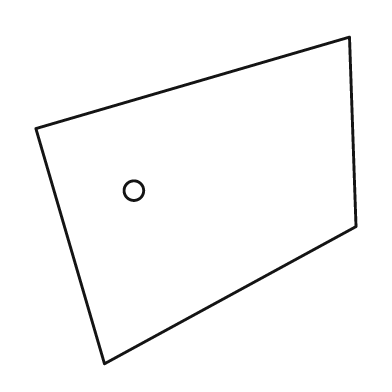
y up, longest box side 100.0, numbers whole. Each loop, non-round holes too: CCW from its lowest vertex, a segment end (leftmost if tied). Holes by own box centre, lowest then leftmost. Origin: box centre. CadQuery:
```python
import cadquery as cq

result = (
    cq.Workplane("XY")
    .moveTo(-28.0, -50.0)
    .lineTo(49.0, -8.0)
    .lineTo(47.0, 50.0)
    .lineTo(-49.0, 22.0)
    .close()
    .moveTo(-19.0, 3.0)
    .circle(3.0)
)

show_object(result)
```